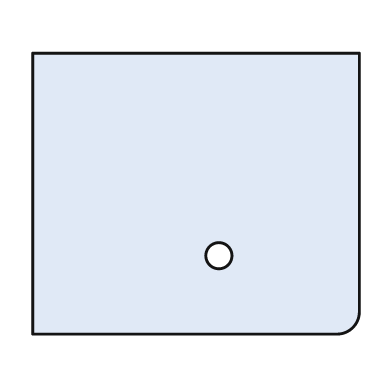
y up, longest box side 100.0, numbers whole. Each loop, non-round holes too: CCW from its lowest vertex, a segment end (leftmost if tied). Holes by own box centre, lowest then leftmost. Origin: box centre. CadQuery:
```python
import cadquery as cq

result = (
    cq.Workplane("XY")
    .moveTo(-50.0, -43.0)
    .lineTo(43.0, -43.0)
    .threePointArc((48.0, -41.0), (50.0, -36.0))
    .lineTo(50.0, 43.0)
    .lineTo(-50.0, 43.0)
    .close()
    .moveTo(7.0, -19.0)
    .circle(4.0)
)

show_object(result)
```